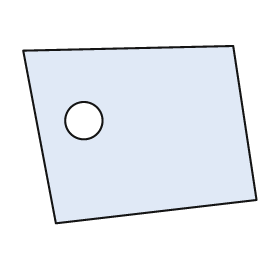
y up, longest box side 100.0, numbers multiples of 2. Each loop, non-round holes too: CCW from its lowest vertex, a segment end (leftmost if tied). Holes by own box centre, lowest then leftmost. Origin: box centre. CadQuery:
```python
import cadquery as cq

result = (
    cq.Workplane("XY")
    .moveTo(-36.0, -38.0)
    .lineTo(50.0, -28.0)
    .lineTo(40.0, 38.0)
    .lineTo(-50.0, 36.0)
    .close()
    .moveTo(-24.0, 6.0)
    .circle(8.0)
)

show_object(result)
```